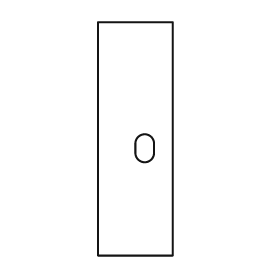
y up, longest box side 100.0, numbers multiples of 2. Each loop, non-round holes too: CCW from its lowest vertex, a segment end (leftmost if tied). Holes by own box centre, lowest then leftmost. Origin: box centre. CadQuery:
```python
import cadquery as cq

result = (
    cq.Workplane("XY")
    .moveTo(-16.0, -50.0)
    .lineTo(16.0, -50.0)
    .lineTo(16.0, 50.0)
    .lineTo(-16.0, 50.0)
    .close()
    .moveTo(0.0, -6.0)
    .threePointArc((4.0, -10.0), (8.0, -6.0))
    .lineTo(8.0, -2.0)
    .threePointArc((4.0, 2.0), (0.0, -2.0))
    .close()
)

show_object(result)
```